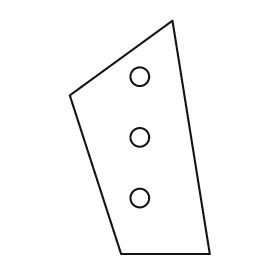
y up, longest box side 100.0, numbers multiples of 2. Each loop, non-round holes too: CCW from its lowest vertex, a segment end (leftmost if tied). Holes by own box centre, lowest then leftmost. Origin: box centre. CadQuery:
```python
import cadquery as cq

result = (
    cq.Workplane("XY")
    .moveTo(-8.0, -50.0)
    .lineTo(30.0, -50.0)
    .lineTo(14.0, 50.0)
    .lineTo(-30.0, 18.0)
    .close()
    .moveTo(0.0, -26.0)
    .circle(4.0)
    .moveTo(0.0, 0.0)
    .circle(4.0)
    .moveTo(0.0, 26.0)
    .circle(4.0)
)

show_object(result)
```